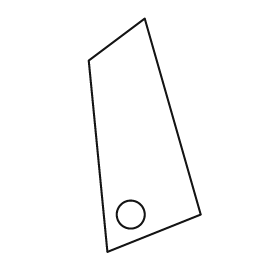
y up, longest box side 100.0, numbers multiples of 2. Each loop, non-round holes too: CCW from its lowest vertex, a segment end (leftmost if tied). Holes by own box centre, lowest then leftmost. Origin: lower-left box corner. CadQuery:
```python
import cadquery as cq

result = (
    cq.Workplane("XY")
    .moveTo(8.0, 0.0)
    .lineTo(48.0, 16.0)
    .lineTo(24.0, 100.0)
    .lineTo(0.0, 82.0)
    .close()
    .moveTo(18.0, 16.0)
    .circle(6.0)
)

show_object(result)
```